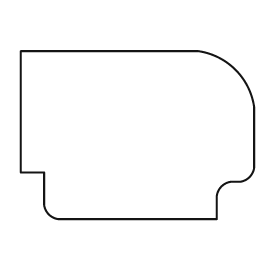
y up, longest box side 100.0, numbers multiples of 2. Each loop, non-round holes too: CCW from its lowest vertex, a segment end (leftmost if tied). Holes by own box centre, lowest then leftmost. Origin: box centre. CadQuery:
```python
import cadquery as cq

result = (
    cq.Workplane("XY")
    .moveTo(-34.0, -36.0)
    .lineTo(34.0, -36.0)
    .lineTo(34.0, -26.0)
    .threePointArc((36.0, -22.0), (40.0, -20.0))
    .lineTo(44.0, -20.0)
    .threePointArc((48.0, -18.0), (50.0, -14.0))
    .lineTo(50.0, 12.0)
    .threePointArc((42.0, 28.0), (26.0, 36.0))
    .lineTo(-50.0, 36.0)
    .lineTo(-50.0, -16.0)
    .lineTo(-40.0, -16.0)
    .lineTo(-40.0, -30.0)
    .threePointArc((-38.0, -34.0), (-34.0, -36.0))
    .close()
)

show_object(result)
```